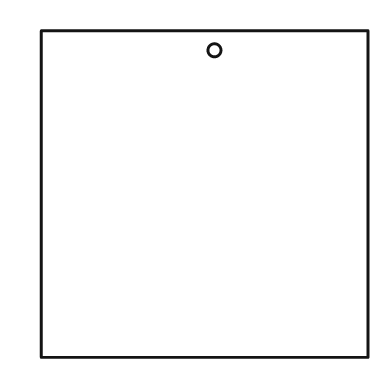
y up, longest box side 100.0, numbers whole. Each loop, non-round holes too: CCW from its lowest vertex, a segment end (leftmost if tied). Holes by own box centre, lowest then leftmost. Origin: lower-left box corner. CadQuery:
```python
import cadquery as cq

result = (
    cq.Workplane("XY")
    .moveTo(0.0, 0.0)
    .lineTo(100.0, 0.0)
    .lineTo(100.0, 100.0)
    .lineTo(0.0, 100.0)
    .close()
    .moveTo(53.0, 94.0)
    .circle(2.0)
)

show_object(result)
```